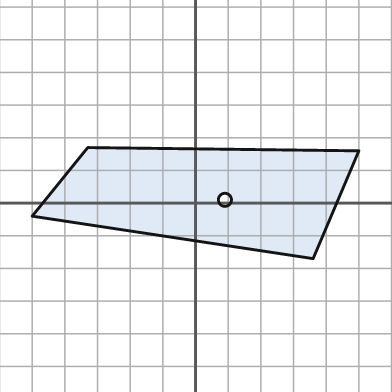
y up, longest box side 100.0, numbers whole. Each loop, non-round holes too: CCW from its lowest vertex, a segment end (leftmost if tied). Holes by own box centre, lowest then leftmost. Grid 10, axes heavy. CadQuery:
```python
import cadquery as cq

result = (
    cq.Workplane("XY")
    .moveTo(36.0, -17.0)
    .lineTo(50.0, 16.0)
    .lineTo(-33.0, 17.0)
    .lineTo(-50.0, -4.0)
    .close()
    .moveTo(9.0, 1.0)
    .circle(2.0)
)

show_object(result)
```